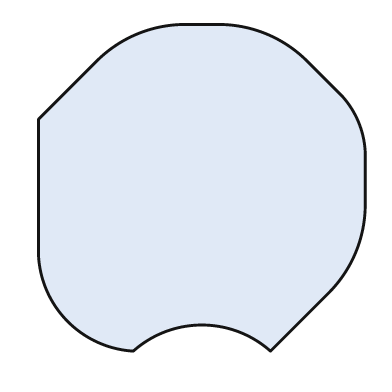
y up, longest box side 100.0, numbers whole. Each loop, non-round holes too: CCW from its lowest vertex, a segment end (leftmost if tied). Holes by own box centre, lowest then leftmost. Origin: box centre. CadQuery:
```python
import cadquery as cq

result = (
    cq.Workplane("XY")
    .moveTo(-21.0, -50.0)
    .threePointArc((0.0, -42.0), (21.0, -50.0))
    .lineTo(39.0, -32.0)
    .threePointArc((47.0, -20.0), (50.0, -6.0))
    .lineTo(50.0, 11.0)
    .threePointArc((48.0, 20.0), (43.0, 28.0))
    .lineTo(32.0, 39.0)
    .threePointArc((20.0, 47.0), (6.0, 50.0))
    .lineTo(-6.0, 50.0)
    .threePointArc((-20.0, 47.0), (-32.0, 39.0))
    .lineTo(-50.0, 21.0)
    .lineTo(-50.0, -21.0)
    .threePointArc((-41.0, -41.0), (-21.0, -50.0))
    .close()
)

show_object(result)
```